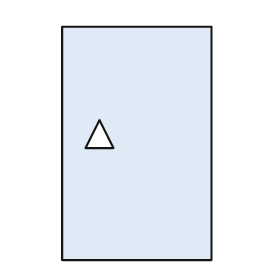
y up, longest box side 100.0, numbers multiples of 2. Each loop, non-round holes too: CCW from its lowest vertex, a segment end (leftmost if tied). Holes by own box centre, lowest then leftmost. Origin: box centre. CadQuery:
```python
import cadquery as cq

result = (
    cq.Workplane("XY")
    .moveTo(-32.0, -50.0)
    .lineTo(32.0, -50.0)
    .lineTo(32.0, 50.0)
    .lineTo(-32.0, 50.0)
    .close()
    .moveTo(-22.0, -2.0)
    .lineTo(-10.0, -2.0)
    .lineTo(-16.0, 10.0)
    .close()
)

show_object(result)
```